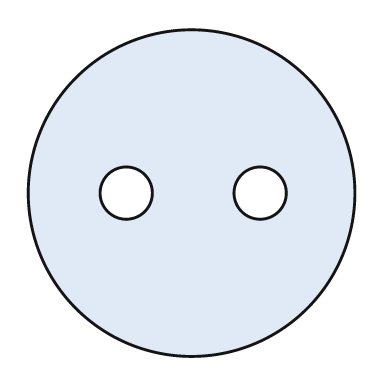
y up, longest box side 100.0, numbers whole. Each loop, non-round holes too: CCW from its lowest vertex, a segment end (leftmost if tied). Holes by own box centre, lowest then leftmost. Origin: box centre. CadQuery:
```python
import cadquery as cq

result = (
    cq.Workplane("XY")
    .moveTo(0.0, 0.0)
    .circle(50.0)
    .moveTo(-20.0, 0.0)
    .circle(8.0)
    .moveTo(21.0, 0.0)
    .circle(8.0)
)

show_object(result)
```